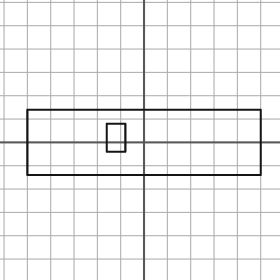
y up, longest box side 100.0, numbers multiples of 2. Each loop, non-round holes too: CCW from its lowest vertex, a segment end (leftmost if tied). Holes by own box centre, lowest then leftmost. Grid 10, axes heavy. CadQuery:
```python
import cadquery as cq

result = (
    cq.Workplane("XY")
    .moveTo(-50.0, -14.0)
    .lineTo(50.0, -14.0)
    .lineTo(50.0, 14.0)
    .lineTo(-50.0, 14.0)
    .close()
    .moveTo(-16.0, -4.0)
    .lineTo(-8.0, -4.0)
    .lineTo(-8.0, 8.0)
    .lineTo(-16.0, 8.0)
    .close()
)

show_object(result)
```